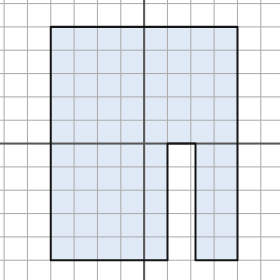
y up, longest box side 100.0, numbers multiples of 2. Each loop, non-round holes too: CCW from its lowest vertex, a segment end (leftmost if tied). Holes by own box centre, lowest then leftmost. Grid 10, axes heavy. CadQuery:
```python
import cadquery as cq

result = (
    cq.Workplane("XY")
    .moveTo(-40.0, -50.0)
    .lineTo(10.0, -50.0)
    .lineTo(10.0, 0.0)
    .lineTo(22.0, 0.0)
    .lineTo(22.0, -50.0)
    .lineTo(40.0, -50.0)
    .lineTo(40.0, 50.0)
    .lineTo(-40.0, 50.0)
    .close()
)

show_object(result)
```